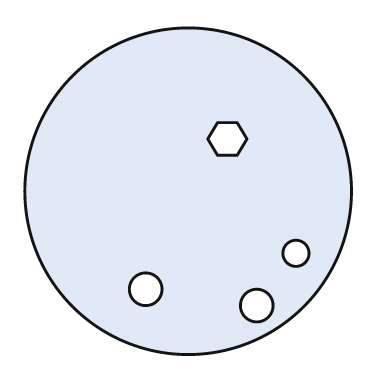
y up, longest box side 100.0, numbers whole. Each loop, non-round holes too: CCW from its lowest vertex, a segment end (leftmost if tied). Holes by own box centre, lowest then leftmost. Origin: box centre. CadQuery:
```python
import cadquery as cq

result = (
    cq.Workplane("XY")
    .moveTo(0.0, 0.0)
    .circle(50.0)
    .moveTo(21.0, -35.0)
    .circle(5.0)
    .moveTo(-13.0, -30.0)
    .circle(5.0)
    .moveTo(33.0, -19.0)
    .circle(4.0)
    .moveTo(9.0, 11.0)
    .lineTo(15.0, 11.0)
    .lineTo(18.0, 16.0)
    .lineTo(15.0, 21.0)
    .lineTo(9.0, 21.0)
    .lineTo(6.0, 16.0)
    .close()
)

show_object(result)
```